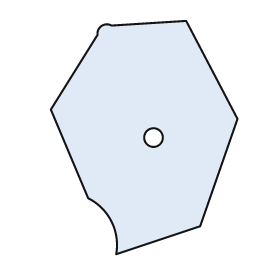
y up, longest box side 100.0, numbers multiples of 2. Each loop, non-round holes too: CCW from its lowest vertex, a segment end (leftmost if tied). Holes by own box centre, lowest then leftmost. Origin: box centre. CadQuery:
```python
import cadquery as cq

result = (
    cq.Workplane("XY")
    .moveTo(-12.0, -50.0)
    .lineTo(24.0, -38.0)
    .lineTo(40.0, 8.0)
    .lineTo(18.0, 50.0)
    .lineTo(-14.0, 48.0)
    .threePointArc((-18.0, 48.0), (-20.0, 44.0))
    .lineTo(-40.0, 12.0)
    .lineTo(-24.0, -26.0)
    .threePointArc((-14.0, -36.0), (-12.0, -50.0))
    .close()
    .moveTo(4.0, 0.0)
    .circle(4.0)
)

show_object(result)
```